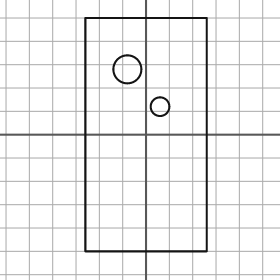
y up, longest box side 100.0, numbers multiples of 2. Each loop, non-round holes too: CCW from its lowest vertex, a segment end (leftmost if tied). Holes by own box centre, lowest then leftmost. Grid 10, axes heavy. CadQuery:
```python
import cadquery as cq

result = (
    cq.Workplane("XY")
    .moveTo(-26.0, -50.0)
    .lineTo(26.0, -50.0)
    .lineTo(26.0, 50.0)
    .lineTo(-26.0, 50.0)
    .close()
    .moveTo(6.0, 12.0)
    .circle(4.0)
    .moveTo(-8.0, 28.0)
    .circle(6.0)
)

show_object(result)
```